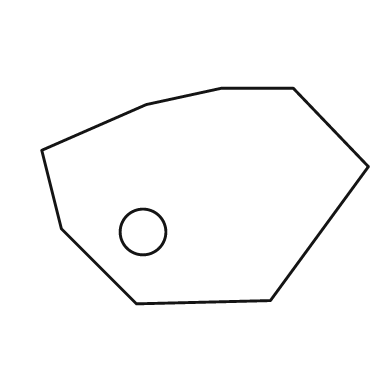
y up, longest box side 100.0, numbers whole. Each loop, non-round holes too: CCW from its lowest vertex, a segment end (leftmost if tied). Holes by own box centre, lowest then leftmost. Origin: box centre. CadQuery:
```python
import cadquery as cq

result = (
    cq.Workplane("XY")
    .moveTo(-21.0, -33.0)
    .lineTo(20.0, -32.0)
    .lineTo(50.0, 9.0)
    .lineTo(27.0, 33.0)
    .lineTo(5.0, 33.0)
    .lineTo(-18.0, 28.0)
    .lineTo(-50.0, 14.0)
    .lineTo(-44.0, -10.0)
    .close()
    .moveTo(-19.0, -11.0)
    .circle(7.0)
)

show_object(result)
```